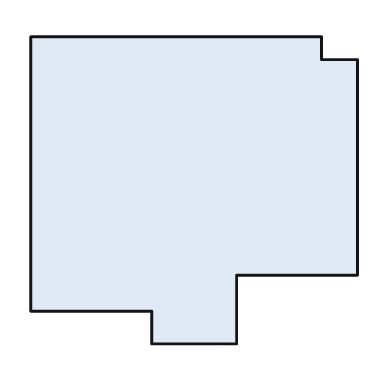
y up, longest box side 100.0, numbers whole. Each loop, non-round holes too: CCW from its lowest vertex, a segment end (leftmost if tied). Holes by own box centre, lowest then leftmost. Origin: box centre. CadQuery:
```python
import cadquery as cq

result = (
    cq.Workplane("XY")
    .moveTo(-13.0, -47.0)
    .lineTo(13.0, -47.0)
    .lineTo(13.0, -26.0)
    .lineTo(50.0, -26.0)
    .lineTo(50.0, 40.0)
    .lineTo(39.0, 40.0)
    .lineTo(39.0, 47.0)
    .lineTo(-50.0, 47.0)
    .lineTo(-50.0, -37.0)
    .lineTo(-13.0, -37.0)
    .close()
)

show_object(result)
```